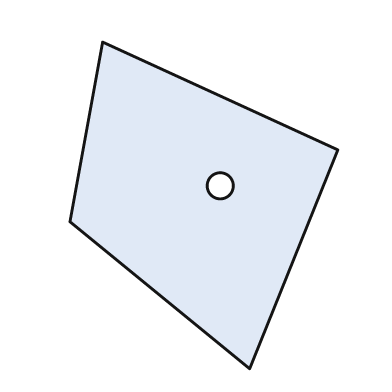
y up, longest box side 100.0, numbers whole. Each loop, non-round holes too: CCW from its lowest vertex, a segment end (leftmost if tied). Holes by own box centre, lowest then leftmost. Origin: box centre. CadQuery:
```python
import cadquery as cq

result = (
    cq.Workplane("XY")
    .moveTo(14.0, -50.0)
    .lineTo(41.0, 17.0)
    .lineTo(-31.0, 50.0)
    .lineTo(-41.0, -5.0)
    .close()
    .moveTo(5.0, 6.0)
    .circle(4.0)
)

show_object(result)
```